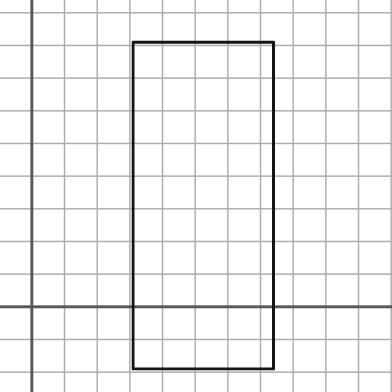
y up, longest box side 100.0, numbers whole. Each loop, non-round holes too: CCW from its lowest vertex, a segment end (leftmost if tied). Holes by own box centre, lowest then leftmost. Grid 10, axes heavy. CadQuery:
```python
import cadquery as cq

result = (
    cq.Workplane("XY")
    .moveTo(31.0, -19.0)
    .lineTo(74.0, -19.0)
    .lineTo(74.0, 81.0)
    .lineTo(31.0, 81.0)
    .close()
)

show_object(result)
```